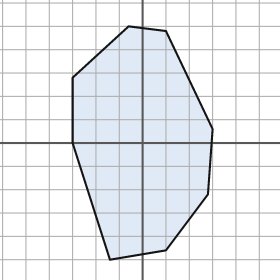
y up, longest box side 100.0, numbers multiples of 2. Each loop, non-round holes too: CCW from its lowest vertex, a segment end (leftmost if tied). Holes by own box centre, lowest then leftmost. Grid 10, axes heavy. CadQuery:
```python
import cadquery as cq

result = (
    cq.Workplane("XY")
    .moveTo(-14.0, -50.0)
    .lineTo(10.0, -46.0)
    .lineTo(28.0, -22.0)
    .lineTo(30.0, 6.0)
    .lineTo(10.0, 48.0)
    .lineTo(-6.0, 50.0)
    .lineTo(-30.0, 28.0)
    .lineTo(-30.0, 0.0)
    .close()
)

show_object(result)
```